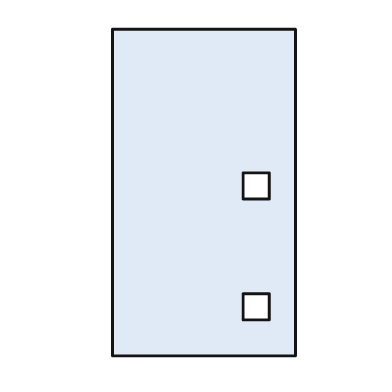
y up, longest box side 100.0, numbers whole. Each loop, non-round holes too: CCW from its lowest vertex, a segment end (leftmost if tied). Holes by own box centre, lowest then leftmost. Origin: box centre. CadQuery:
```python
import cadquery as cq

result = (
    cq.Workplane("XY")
    .moveTo(-28.0, -50.0)
    .lineTo(28.0, -50.0)
    .lineTo(28.0, 50.0)
    .lineTo(-28.0, 50.0)
    .close()
    .moveTo(12.0, -39.0)
    .lineTo(20.0, -39.0)
    .lineTo(20.0, -31.0)
    .lineTo(12.0, -31.0)
    .close()
    .moveTo(12.0, -2.0)
    .lineTo(20.0, -2.0)
    .lineTo(20.0, 6.0)
    .lineTo(12.0, 6.0)
    .close()
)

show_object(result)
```